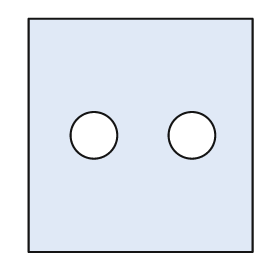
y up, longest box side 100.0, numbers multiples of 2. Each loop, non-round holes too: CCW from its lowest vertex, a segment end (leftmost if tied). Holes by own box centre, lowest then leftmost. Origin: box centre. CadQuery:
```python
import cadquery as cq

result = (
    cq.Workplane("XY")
    .moveTo(-48.0, -50.0)
    .lineTo(48.0, -50.0)
    .lineTo(48.0, 50.0)
    .lineTo(-48.0, 50.0)
    .close()
    .moveTo(-20.0, 0.0)
    .circle(10.0)
    .moveTo(22.0, 0.0)
    .circle(10.0)
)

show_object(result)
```